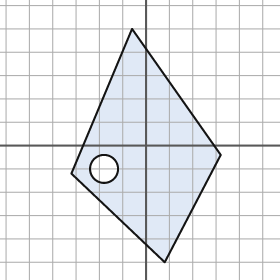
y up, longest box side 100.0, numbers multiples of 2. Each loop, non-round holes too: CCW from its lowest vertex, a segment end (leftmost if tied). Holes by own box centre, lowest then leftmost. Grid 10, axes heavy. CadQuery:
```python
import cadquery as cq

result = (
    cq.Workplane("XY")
    .moveTo(8.0, -50.0)
    .lineTo(32.0, -4.0)
    .lineTo(-6.0, 50.0)
    .lineTo(-32.0, -12.0)
    .close()
    .moveTo(-18.0, -10.0)
    .circle(6.0)
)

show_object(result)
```